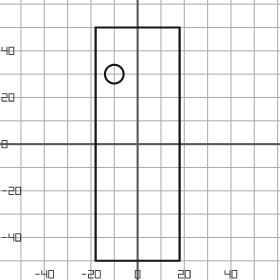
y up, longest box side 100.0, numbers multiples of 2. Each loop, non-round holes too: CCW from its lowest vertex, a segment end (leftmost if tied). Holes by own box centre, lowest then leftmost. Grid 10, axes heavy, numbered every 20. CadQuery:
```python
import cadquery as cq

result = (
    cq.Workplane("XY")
    .moveTo(-18.0, -50.0)
    .lineTo(18.0, -50.0)
    .lineTo(18.0, 50.0)
    .lineTo(-18.0, 50.0)
    .close()
    .moveTo(-10.0, 30.0)
    .circle(4.0)
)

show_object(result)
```